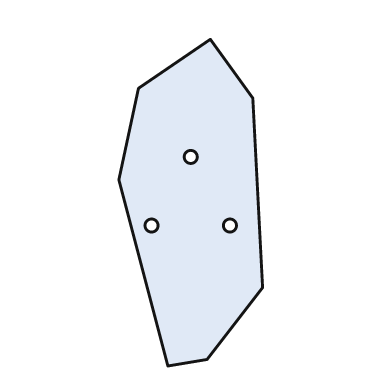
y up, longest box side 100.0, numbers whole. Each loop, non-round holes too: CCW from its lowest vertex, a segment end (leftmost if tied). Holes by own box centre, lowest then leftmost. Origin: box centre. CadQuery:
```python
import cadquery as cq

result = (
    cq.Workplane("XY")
    .moveTo(-7.0, -50.0)
    .lineTo(5.0, -48.0)
    .lineTo(22.0, -26.0)
    .lineTo(19.0, 32.0)
    .lineTo(6.0, 50.0)
    .lineTo(-16.0, 35.0)
    .lineTo(-22.0, 7.0)
    .close()
    .moveTo(-12.0, -7.0)
    .circle(2.0)
    .moveTo(12.0, -7.0)
    .circle(2.0)
    .moveTo(0.0, 14.0)
    .circle(2.0)
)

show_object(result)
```